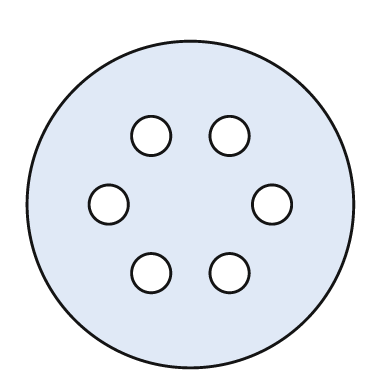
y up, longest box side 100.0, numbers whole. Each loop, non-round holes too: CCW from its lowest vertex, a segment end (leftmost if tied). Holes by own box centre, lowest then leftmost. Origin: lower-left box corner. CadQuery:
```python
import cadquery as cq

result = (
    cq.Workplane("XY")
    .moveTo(50.0, 50.0)
    .circle(50.0)
    .moveTo(38.0, 29.0)
    .circle(6.0)
    .moveTo(62.0, 29.0)
    .circle(6.0)
    .moveTo(25.0, 50.0)
    .circle(6.0)
    .moveTo(75.0, 50.0)
    .circle(6.0)
    .moveTo(38.0, 71.0)
    .circle(6.0)
    .moveTo(62.0, 71.0)
    .circle(6.0)
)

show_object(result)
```